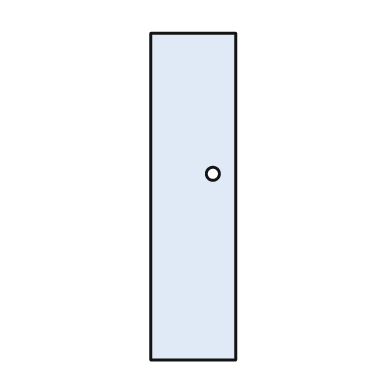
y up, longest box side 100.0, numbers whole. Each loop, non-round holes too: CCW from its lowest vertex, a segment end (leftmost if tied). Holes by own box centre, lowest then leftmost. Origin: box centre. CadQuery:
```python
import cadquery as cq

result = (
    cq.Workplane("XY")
    .moveTo(-13.0, -50.0)
    .lineTo(13.0, -50.0)
    .lineTo(13.0, 50.0)
    .lineTo(-13.0, 50.0)
    .close()
    .moveTo(6.0, 7.0)
    .circle(2.0)
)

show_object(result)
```